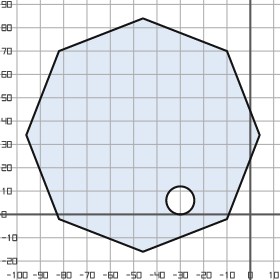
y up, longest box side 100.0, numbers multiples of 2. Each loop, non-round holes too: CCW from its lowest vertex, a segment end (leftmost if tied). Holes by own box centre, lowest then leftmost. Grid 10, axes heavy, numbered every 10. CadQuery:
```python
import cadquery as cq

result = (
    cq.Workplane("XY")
    .moveTo(-46.0, -16.0)
    .lineTo(-10.0, -2.0)
    .lineTo(4.0, 34.0)
    .lineTo(-10.0, 70.0)
    .lineTo(-46.0, 84.0)
    .lineTo(-82.0, 70.0)
    .lineTo(-96.0, 34.0)
    .lineTo(-82.0, -2.0)
    .close()
    .moveTo(-30.0, 6.0)
    .circle(6.0)
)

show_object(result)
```